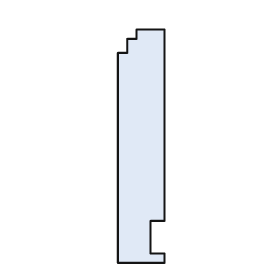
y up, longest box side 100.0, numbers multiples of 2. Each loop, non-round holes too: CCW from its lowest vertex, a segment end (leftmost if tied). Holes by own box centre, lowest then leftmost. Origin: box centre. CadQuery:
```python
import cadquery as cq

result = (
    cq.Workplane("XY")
    .moveTo(-10.0, -50.0)
    .lineTo(10.0, -50.0)
    .lineTo(10.0, -46.0)
    .lineTo(4.0, -46.0)
    .lineTo(4.0, -32.0)
    .lineTo(10.0, -32.0)
    .lineTo(10.0, 50.0)
    .lineTo(-2.0, 50.0)
    .lineTo(-2.0, 46.0)
    .lineTo(-6.0, 46.0)
    .lineTo(-6.0, 40.0)
    .lineTo(-10.0, 40.0)
    .close()
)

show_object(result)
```